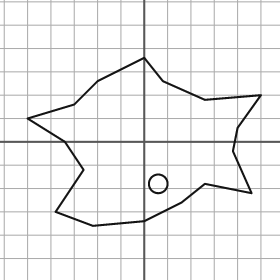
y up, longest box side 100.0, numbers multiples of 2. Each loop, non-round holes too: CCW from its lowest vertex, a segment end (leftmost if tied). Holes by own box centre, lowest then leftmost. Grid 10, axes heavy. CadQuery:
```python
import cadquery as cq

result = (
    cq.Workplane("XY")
    .moveTo(-22.0, -36.0)
    .lineTo(0.0, -34.0)
    .lineTo(16.0, -26.0)
    .lineTo(26.0, -18.0)
    .lineTo(46.0, -22.0)
    .lineTo(38.0, -4.0)
    .lineTo(40.0, 6.0)
    .lineTo(50.0, 20.0)
    .lineTo(26.0, 18.0)
    .lineTo(8.0, 26.0)
    .lineTo(0.0, 36.0)
    .lineTo(-20.0, 26.0)
    .lineTo(-30.0, 16.0)
    .lineTo(-50.0, 10.0)
    .lineTo(-34.0, 0.0)
    .lineTo(-26.0, -12.0)
    .lineTo(-38.0, -30.0)
    .close()
    .moveTo(6.0, -18.0)
    .circle(4.0)
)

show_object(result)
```